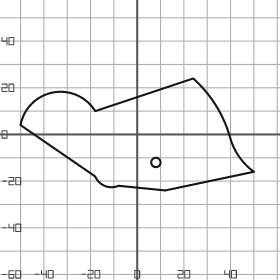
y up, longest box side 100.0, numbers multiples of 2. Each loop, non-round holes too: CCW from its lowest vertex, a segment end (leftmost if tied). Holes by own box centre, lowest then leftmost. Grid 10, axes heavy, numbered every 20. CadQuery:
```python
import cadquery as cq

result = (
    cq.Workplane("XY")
    .moveTo(12.0, -24.0)
    .lineTo(50.0, -16.0)
    .threePointArc((44.0, -10.0), (40.0, -2.0))
    .threePointArc((34.0, 12.0), (24.0, 24.0))
    .lineTo(-18.0, 10.0)
    .threePointArc((-36.0, 18.0), (-50.0, 4.0))
    .lineTo(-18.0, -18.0)
    .threePointArc((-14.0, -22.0), (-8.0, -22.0))
    .close()
    .moveTo(8.0, -12.0)
    .circle(2.0)
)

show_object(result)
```